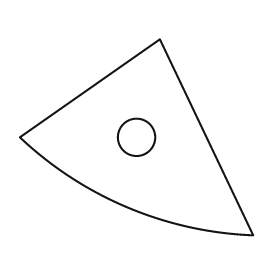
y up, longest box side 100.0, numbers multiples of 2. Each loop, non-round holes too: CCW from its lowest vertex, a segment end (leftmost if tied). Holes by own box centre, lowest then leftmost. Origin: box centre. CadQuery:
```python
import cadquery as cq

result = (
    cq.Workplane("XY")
    .moveTo(50.0, -42.0)
    .lineTo(10.0, 42.0)
    .lineTo(-50.0, 0.0)
    .threePointArc((-4.0, -30.0), (50.0, -42.0))
    .close()
    .moveTo(0.0, 0.0)
    .circle(8.0)
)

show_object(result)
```